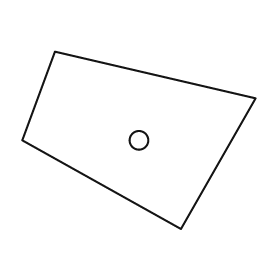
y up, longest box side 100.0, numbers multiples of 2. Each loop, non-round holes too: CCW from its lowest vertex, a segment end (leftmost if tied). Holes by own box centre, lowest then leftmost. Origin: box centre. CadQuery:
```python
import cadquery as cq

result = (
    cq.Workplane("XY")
    .moveTo(18.0, -38.0)
    .lineTo(50.0, 18.0)
    .lineTo(-36.0, 38.0)
    .lineTo(-50.0, 0.0)
    .close()
    .moveTo(0.0, 0.0)
    .circle(4.0)
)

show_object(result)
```